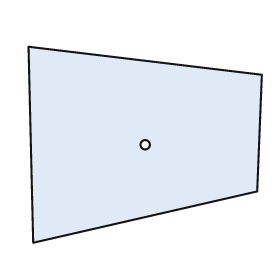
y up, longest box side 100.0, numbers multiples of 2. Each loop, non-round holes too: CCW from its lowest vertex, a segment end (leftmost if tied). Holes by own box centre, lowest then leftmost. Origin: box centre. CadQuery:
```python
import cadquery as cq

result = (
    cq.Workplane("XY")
    .moveTo(-48.0, -42.0)
    .lineTo(48.0, -20.0)
    .lineTo(50.0, 30.0)
    .lineTo(-50.0, 42.0)
    .close()
    .moveTo(0.0, 0.0)
    .circle(2.0)
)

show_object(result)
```